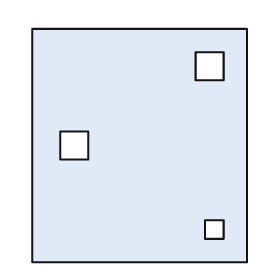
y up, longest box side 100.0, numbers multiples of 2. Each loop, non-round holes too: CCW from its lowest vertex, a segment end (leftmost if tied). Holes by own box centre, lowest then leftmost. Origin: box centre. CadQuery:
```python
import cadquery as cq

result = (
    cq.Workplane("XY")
    .moveTo(-46.0, -50.0)
    .lineTo(46.0, -50.0)
    .lineTo(46.0, 50.0)
    .lineTo(-46.0, 50.0)
    .close()
    .moveTo(28.0, -40.0)
    .lineTo(36.0, -40.0)
    .lineTo(36.0, -32.0)
    .lineTo(28.0, -32.0)
    .close()
    .moveTo(-34.0, -6.0)
    .lineTo(-22.0, -6.0)
    .lineTo(-22.0, 6.0)
    .lineTo(-34.0, 6.0)
    .close()
    .moveTo(24.0, 28.0)
    .lineTo(36.0, 28.0)
    .lineTo(36.0, 40.0)
    .lineTo(24.0, 40.0)
    .close()
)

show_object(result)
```